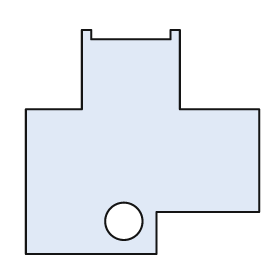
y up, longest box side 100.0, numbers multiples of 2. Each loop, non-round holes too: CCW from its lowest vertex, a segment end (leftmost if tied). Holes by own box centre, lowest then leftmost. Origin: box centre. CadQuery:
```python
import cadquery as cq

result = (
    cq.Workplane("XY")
    .moveTo(-50.0, -48.0)
    .lineTo(6.0, -48.0)
    .lineTo(6.0, -30.0)
    .lineTo(50.0, -30.0)
    .lineTo(50.0, 14.0)
    .lineTo(16.0, 14.0)
    .lineTo(16.0, 48.0)
    .lineTo(12.0, 48.0)
    .lineTo(12.0, 44.0)
    .lineTo(-22.0, 44.0)
    .lineTo(-22.0, 48.0)
    .lineTo(-26.0, 48.0)
    .lineTo(-26.0, 14.0)
    .lineTo(-50.0, 14.0)
    .close()
    .moveTo(-8.0, -34.0)
    .circle(8.0)
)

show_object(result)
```